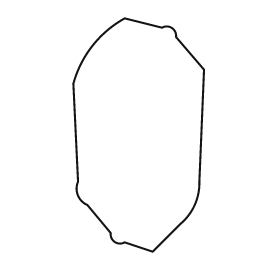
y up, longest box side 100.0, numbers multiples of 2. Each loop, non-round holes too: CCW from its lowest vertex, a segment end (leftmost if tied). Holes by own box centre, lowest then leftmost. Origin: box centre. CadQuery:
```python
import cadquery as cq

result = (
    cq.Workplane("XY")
    .moveTo(6.0, -50.0)
    .lineTo(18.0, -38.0)
    .threePointArc((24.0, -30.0), (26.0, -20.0))
    .lineTo(28.0, 28.0)
    .lineTo(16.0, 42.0)
    .threePointArc((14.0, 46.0), (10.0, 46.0))
    .lineTo(-6.0, 50.0)
    .threePointArc((-20.0, 38.0), (-28.0, 22.0))
    .lineTo(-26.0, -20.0)
    .threePointArc((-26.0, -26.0), (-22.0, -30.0))
    .lineTo(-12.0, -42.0)
    .threePointArc((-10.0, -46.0), (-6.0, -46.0))
    .close()
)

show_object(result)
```